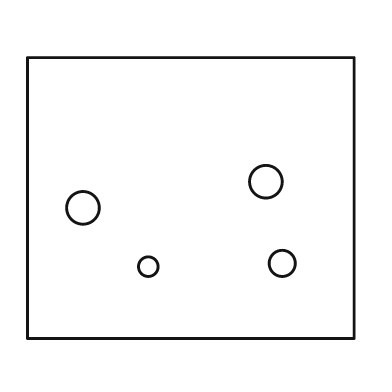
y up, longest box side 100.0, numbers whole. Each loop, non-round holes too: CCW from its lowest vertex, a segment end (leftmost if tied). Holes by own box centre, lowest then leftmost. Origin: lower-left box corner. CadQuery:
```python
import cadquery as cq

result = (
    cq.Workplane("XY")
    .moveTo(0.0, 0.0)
    .lineTo(100.0, 0.0)
    .lineTo(100.0, 86.0)
    .lineTo(0.0, 86.0)
    .close()
    .moveTo(37.0, 22.0)
    .circle(3.0)
    .moveTo(78.0, 23.0)
    .circle(4.0)
    .moveTo(17.0, 40.0)
    .circle(5.0)
    .moveTo(73.0, 48.0)
    .circle(5.0)
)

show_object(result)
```